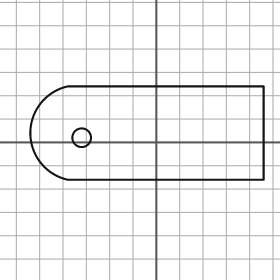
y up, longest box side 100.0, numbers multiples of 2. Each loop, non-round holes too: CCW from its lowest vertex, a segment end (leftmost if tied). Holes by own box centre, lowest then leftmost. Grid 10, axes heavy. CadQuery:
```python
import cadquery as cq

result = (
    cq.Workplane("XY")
    .moveTo(-38.0, -16.0)
    .lineTo(46.0, -16.0)
    .lineTo(46.0, 24.0)
    .lineTo(-38.0, 24.0)
    .threePointArc((-54.0, 4.0), (-38.0, -16.0))
    .close()
    .moveTo(-32.0, 2.0)
    .circle(4.0)
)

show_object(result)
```